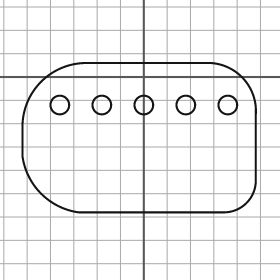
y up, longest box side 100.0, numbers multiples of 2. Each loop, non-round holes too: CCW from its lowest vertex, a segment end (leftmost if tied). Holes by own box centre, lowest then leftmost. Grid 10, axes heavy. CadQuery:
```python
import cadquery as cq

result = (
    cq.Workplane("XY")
    .moveTo(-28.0, -58.0)
    .lineTo(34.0, -58.0)
    .threePointArc((44.0, -54.0), (48.0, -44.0))
    .lineTo(48.0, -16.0)
    .threePointArc((42.0, 0.0), (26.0, 6.0))
    .lineTo(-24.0, 6.0)
    .threePointArc((-44.0, -2.0), (-52.0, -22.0))
    .lineTo(-52.0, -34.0)
    .threePointArc((-44.0, -50.0), (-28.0, -58.0))
    .close()
    .moveTo(-36.0, -12.0)
    .circle(4.0)
    .moveTo(-18.0, -12.0)
    .circle(4.0)
    .moveTo(0.0, -12.0)
    .circle(4.0)
    .moveTo(18.0, -12.0)
    .circle(4.0)
    .moveTo(36.0, -12.0)
    .circle(4.0)
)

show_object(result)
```